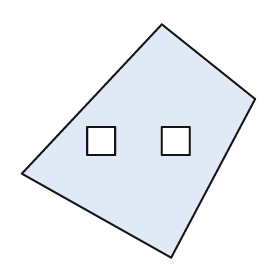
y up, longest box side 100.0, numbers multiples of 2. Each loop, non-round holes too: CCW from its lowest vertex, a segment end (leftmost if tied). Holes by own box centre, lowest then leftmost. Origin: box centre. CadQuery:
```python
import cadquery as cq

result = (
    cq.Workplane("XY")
    .moveTo(14.0, -50.0)
    .lineTo(50.0, 18.0)
    .lineTo(10.0, 50.0)
    .lineTo(-50.0, -14.0)
    .close()
    .moveTo(-22.0, -6.0)
    .lineTo(-10.0, -6.0)
    .lineTo(-10.0, 6.0)
    .lineTo(-22.0, 6.0)
    .close()
    .moveTo(10.0, -6.0)
    .lineTo(22.0, -6.0)
    .lineTo(22.0, 6.0)
    .lineTo(10.0, 6.0)
    .close()
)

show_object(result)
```